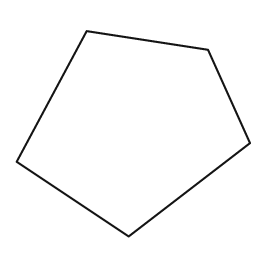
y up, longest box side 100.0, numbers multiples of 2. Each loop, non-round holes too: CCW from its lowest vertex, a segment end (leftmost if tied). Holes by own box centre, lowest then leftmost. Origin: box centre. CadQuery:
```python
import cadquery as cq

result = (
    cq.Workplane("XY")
    .moveTo(-2.0, -44.0)
    .lineTo(50.0, -4.0)
    .lineTo(32.0, 36.0)
    .lineTo(-20.0, 44.0)
    .lineTo(-50.0, -12.0)
    .close()
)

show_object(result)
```